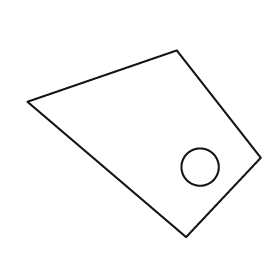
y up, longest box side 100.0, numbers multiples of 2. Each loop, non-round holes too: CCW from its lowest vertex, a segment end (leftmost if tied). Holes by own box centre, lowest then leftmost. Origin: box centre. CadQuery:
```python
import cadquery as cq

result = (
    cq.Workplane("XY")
    .moveTo(18.0, -40.0)
    .lineTo(50.0, -6.0)
    .lineTo(14.0, 40.0)
    .lineTo(-50.0, 18.0)
    .close()
    .moveTo(24.0, -10.0)
    .circle(8.0)
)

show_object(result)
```